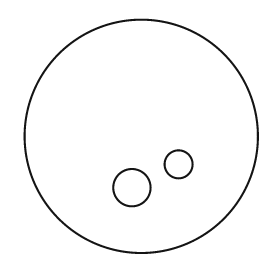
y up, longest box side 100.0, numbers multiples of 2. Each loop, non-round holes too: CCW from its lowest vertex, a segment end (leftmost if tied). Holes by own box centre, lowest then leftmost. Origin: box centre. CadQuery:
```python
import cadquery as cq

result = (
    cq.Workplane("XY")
    .moveTo(0.0, 0.0)
    .circle(50.0)
    .moveTo(-4.0, -22.0)
    .circle(8.0)
    .moveTo(16.0, -12.0)
    .circle(6.0)
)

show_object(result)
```